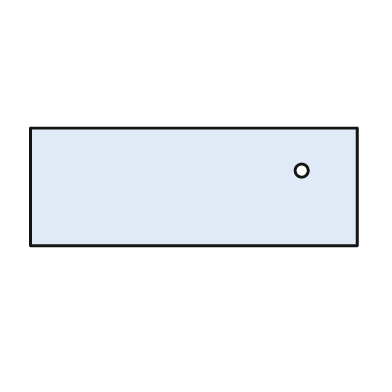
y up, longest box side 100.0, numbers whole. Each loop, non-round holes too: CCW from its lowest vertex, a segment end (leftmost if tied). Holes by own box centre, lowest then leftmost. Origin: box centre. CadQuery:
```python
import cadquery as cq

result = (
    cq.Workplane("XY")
    .moveTo(-50.0, -18.0)
    .lineTo(50.0, -18.0)
    .lineTo(50.0, 18.0)
    .lineTo(-50.0, 18.0)
    .close()
    .moveTo(33.0, 5.0)
    .circle(2.0)
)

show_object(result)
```